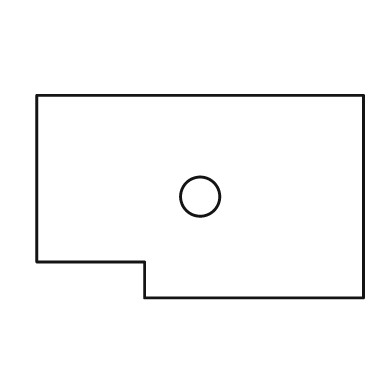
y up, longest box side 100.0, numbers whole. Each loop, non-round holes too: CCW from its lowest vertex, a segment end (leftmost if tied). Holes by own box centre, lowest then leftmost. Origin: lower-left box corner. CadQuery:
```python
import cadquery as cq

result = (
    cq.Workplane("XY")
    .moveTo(33.0, 0.0)
    .lineTo(100.0, 0.0)
    .lineTo(100.0, 62.0)
    .lineTo(0.0, 62.0)
    .lineTo(0.0, 11.0)
    .lineTo(33.0, 11.0)
    .close()
    .moveTo(50.0, 31.0)
    .circle(6.0)
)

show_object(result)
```